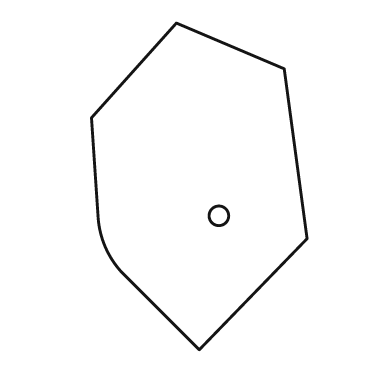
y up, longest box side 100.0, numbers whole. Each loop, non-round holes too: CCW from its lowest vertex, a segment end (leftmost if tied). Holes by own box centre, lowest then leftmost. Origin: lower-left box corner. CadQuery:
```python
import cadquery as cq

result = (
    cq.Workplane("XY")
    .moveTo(33.0, 0.0)
    .lineTo(66.0, 34.0)
    .lineTo(59.0, 86.0)
    .lineTo(26.0, 100.0)
    .lineTo(0.0, 71.0)
    .lineTo(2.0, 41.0)
    .threePointArc((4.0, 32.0), (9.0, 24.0))
    .close()
    .moveTo(39.0, 41.0)
    .circle(3.0)
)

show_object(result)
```